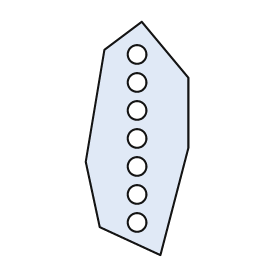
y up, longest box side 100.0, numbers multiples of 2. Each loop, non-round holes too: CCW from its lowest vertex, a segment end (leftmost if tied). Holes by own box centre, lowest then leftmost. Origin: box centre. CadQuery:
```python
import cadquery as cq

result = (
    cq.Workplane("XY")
    .moveTo(10.0, -50.0)
    .lineTo(22.0, -4.0)
    .lineTo(22.0, 26.0)
    .lineTo(2.0, 50.0)
    .lineTo(-14.0, 38.0)
    .lineTo(-22.0, -10.0)
    .lineTo(-16.0, -38.0)
    .close()
    .moveTo(0.0, -36.0)
    .circle(4.0)
    .moveTo(0.0, -24.0)
    .circle(4.0)
    .moveTo(0.0, -12.0)
    .circle(4.0)
    .moveTo(0.0, 0.0)
    .circle(4.0)
    .moveTo(0.0, 12.0)
    .circle(4.0)
    .moveTo(0.0, 24.0)
    .circle(4.0)
    .moveTo(0.0, 36.0)
    .circle(4.0)
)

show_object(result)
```